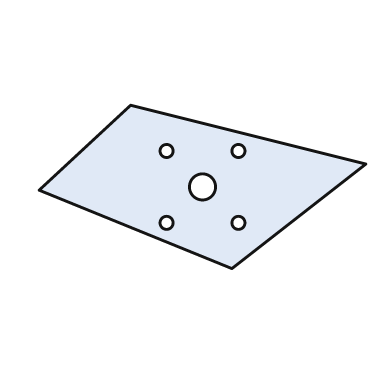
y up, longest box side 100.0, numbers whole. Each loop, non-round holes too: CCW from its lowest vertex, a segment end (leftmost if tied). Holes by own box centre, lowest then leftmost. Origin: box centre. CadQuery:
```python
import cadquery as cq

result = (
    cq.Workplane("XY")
    .moveTo(9.0, -25.0)
    .lineTo(50.0, 7.0)
    .lineTo(-22.0, 25.0)
    .lineTo(-50.0, -1.0)
    .close()
    .moveTo(-11.0, -11.0)
    .circle(2.0)
    .moveTo(11.0, -11.0)
    .circle(2.0)
    .moveTo(0.0, 0.0)
    .circle(4.0)
    .moveTo(-11.0, 11.0)
    .circle(2.0)
    .moveTo(11.0, 11.0)
    .circle(2.0)
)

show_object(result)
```